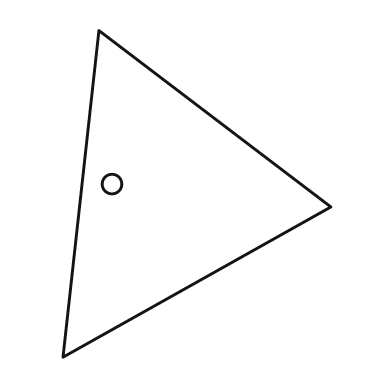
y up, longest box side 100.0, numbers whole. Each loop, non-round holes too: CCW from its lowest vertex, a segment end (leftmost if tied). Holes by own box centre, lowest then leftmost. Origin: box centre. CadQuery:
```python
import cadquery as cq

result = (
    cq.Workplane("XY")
    .moveTo(-41.0, -50.0)
    .lineTo(41.0, -4.0)
    .lineTo(-30.0, 50.0)
    .close()
    .moveTo(-26.0, 3.0)
    .circle(3.0)
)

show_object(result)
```